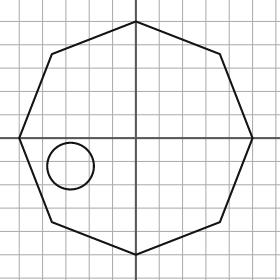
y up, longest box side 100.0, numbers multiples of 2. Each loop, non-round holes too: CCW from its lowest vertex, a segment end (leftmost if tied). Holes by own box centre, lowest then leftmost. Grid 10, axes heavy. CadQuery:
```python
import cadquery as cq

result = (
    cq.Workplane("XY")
    .moveTo(0.0, -50.0)
    .lineTo(36.0, -36.0)
    .lineTo(50.0, 0.0)
    .lineTo(36.0, 36.0)
    .lineTo(0.0, 50.0)
    .lineTo(-36.0, 36.0)
    .lineTo(-50.0, 0.0)
    .lineTo(-36.0, -36.0)
    .close()
    .moveTo(-28.0, -12.0)
    .circle(10.0)
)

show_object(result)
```